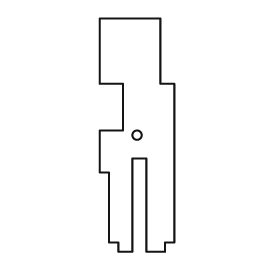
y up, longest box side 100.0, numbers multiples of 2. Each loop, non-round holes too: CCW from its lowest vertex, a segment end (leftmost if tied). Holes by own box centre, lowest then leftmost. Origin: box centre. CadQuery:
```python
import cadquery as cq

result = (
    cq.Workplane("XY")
    .moveTo(-8.0, -50.0)
    .lineTo(-2.0, -50.0)
    .lineTo(-2.0, -10.0)
    .lineTo(4.0, -10.0)
    .lineTo(4.0, -50.0)
    .lineTo(12.0, -50.0)
    .lineTo(12.0, -46.0)
    .lineTo(16.0, -46.0)
    .lineTo(16.0, 22.0)
    .lineTo(10.0, 22.0)
    .lineTo(10.0, 50.0)
    .lineTo(-16.0, 50.0)
    .lineTo(-16.0, 22.0)
    .lineTo(-6.0, 22.0)
    .lineTo(-6.0, 2.0)
    .lineTo(-16.0, 2.0)
    .lineTo(-16.0, -16.0)
    .lineTo(-12.0, -16.0)
    .lineTo(-12.0, -46.0)
    .lineTo(-8.0, -46.0)
    .close()
    .moveTo(0.0, 0.0)
    .circle(2.0)
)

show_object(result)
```